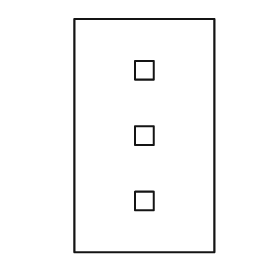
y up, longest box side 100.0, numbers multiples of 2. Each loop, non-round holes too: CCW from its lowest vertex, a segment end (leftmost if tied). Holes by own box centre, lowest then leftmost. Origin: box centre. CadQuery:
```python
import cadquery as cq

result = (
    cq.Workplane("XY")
    .moveTo(-30.0, -50.0)
    .lineTo(30.0, -50.0)
    .lineTo(30.0, 50.0)
    .lineTo(-30.0, 50.0)
    .close()
    .moveTo(-4.0, -32.0)
    .lineTo(4.0, -32.0)
    .lineTo(4.0, -24.0)
    .lineTo(-4.0, -24.0)
    .close()
    .moveTo(-4.0, -4.0)
    .lineTo(4.0, -4.0)
    .lineTo(4.0, 4.0)
    .lineTo(-4.0, 4.0)
    .close()
    .moveTo(-4.0, 24.0)
    .lineTo(4.0, 24.0)
    .lineTo(4.0, 32.0)
    .lineTo(-4.0, 32.0)
    .close()
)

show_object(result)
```